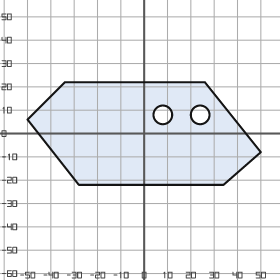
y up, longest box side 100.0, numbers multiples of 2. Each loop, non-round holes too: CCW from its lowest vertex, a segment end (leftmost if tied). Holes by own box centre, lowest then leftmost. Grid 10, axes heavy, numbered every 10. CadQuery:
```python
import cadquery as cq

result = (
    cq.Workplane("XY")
    .moveTo(-28.0, -22.0)
    .lineTo(34.0, -22.0)
    .lineTo(50.0, -8.0)
    .lineTo(26.0, 22.0)
    .lineTo(-34.0, 22.0)
    .lineTo(-50.0, 6.0)
    .close()
    .moveTo(8.0, 8.0)
    .circle(4.0)
    .moveTo(24.0, 8.0)
    .circle(4.0)
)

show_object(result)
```